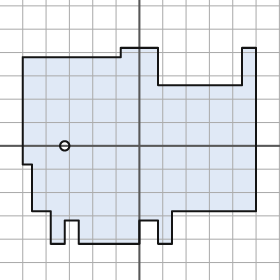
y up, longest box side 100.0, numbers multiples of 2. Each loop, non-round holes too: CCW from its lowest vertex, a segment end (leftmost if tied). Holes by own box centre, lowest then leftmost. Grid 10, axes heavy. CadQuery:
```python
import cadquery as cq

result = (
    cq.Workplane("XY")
    .moveTo(-38.0, -42.0)
    .lineTo(-32.0, -42.0)
    .lineTo(-32.0, -32.0)
    .lineTo(-26.0, -32.0)
    .lineTo(-26.0, -42.0)
    .lineTo(0.0, -42.0)
    .lineTo(0.0, -32.0)
    .lineTo(8.0, -32.0)
    .lineTo(8.0, -42.0)
    .lineTo(14.0, -42.0)
    .lineTo(14.0, -28.0)
    .lineTo(50.0, -28.0)
    .lineTo(50.0, 42.0)
    .lineTo(44.0, 42.0)
    .lineTo(44.0, 26.0)
    .lineTo(8.0, 26.0)
    .lineTo(8.0, 42.0)
    .lineTo(-8.0, 42.0)
    .lineTo(-8.0, 38.0)
    .lineTo(-50.0, 38.0)
    .lineTo(-50.0, -8.0)
    .lineTo(-46.0, -8.0)
    .lineTo(-46.0, -28.0)
    .lineTo(-38.0, -28.0)
    .close()
    .moveTo(-32.0, 0.0)
    .circle(2.0)
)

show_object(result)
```